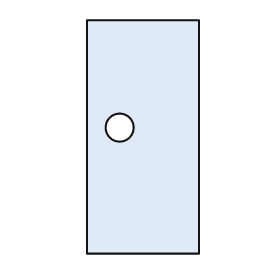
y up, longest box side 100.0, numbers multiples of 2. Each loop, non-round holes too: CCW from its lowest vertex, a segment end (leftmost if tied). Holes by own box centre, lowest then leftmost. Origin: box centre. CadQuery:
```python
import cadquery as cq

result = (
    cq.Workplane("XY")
    .moveTo(-24.0, -50.0)
    .lineTo(24.0, -50.0)
    .lineTo(24.0, 50.0)
    .lineTo(-24.0, 50.0)
    .close()
    .moveTo(-10.0, 4.0)
    .circle(6.0)
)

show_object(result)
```